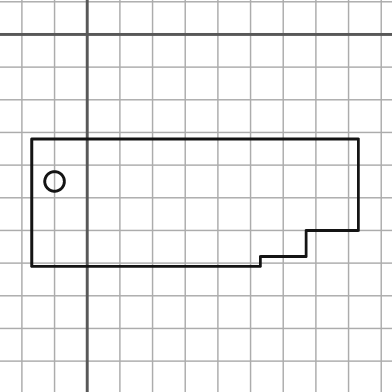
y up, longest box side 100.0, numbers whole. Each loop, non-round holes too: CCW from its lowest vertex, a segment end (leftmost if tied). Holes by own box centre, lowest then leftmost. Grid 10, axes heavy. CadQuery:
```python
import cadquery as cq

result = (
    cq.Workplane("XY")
    .moveTo(-17.0, -71.0)
    .lineTo(53.0, -71.0)
    .lineTo(53.0, -68.0)
    .lineTo(67.0, -68.0)
    .lineTo(67.0, -60.0)
    .lineTo(83.0, -60.0)
    .lineTo(83.0, -32.0)
    .lineTo(-17.0, -32.0)
    .close()
    .moveTo(-10.0, -45.0)
    .circle(3.0)
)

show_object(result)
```